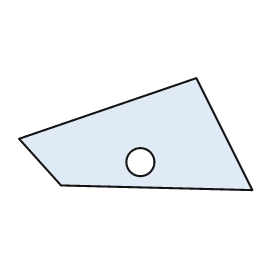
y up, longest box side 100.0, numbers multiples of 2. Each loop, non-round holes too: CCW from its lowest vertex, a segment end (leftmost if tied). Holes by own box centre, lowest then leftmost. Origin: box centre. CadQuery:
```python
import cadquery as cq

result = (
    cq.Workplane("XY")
    .moveTo(50.0, -24.0)
    .lineTo(26.0, 24.0)
    .lineTo(-50.0, -2.0)
    .lineTo(-32.0, -22.0)
    .close()
    .moveTo(2.0, -12.0)
    .circle(6.0)
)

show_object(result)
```